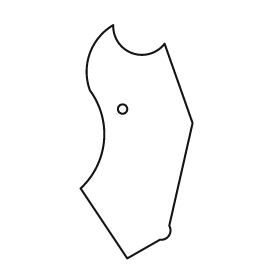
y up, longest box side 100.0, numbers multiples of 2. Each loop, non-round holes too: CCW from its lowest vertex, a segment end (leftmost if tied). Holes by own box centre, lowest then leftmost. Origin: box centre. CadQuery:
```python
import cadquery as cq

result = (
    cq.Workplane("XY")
    .moveTo(-4.0, -50.0)
    .lineTo(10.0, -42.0)
    .threePointArc((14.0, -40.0), (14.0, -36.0))
    .lineTo(24.0, 8.0)
    .lineTo(12.0, 42.0)
    .threePointArc((-2.0, 38.0), (-10.0, 50.0))
    .threePointArc((-20.0, 38.0), (-20.0, 22.0))
    .threePointArc((-14.0, 0.0), (-24.0, -20.0))
    .close()
    .moveTo(-6.0, 14.0)
    .circle(2.0)
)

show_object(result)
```